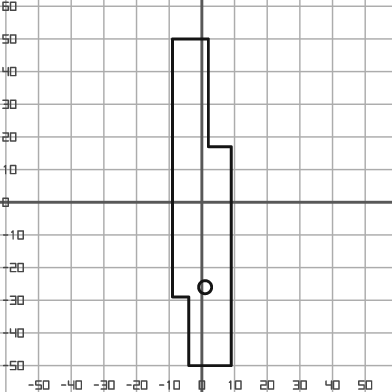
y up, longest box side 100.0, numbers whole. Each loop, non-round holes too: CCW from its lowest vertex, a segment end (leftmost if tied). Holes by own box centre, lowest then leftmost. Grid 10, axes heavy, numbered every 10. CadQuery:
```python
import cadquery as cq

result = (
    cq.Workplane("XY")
    .moveTo(-4.0, -50.0)
    .lineTo(9.0, -50.0)
    .lineTo(9.0, 17.0)
    .lineTo(2.0, 17.0)
    .lineTo(2.0, 50.0)
    .lineTo(-9.0, 50.0)
    .lineTo(-9.0, -29.0)
    .lineTo(-4.0, -29.0)
    .close()
    .moveTo(1.0, -26.0)
    .circle(2.0)
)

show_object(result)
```